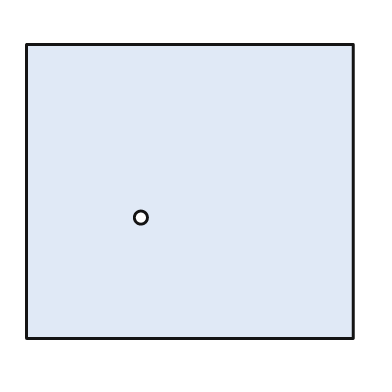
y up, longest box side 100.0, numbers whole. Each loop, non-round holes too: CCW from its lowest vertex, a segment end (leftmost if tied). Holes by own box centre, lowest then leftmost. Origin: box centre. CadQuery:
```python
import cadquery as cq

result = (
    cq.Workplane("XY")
    .moveTo(-50.0, -45.0)
    .lineTo(50.0, -45.0)
    .lineTo(50.0, 45.0)
    .lineTo(-50.0, 45.0)
    .close()
    .moveTo(-15.0, -8.0)
    .circle(2.0)
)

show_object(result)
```